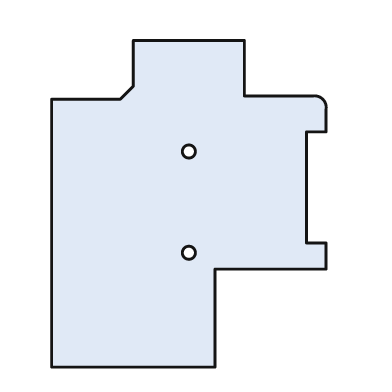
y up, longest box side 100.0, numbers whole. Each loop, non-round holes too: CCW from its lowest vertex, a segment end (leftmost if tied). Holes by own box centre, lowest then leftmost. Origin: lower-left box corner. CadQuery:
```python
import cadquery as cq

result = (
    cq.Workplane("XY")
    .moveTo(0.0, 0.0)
    .lineTo(50.0, 0.0)
    .lineTo(50.0, 30.0)
    .lineTo(84.0, 30.0)
    .lineTo(84.0, 38.0)
    .lineTo(78.0, 38.0)
    .lineTo(78.0, 72.0)
    .lineTo(84.0, 72.0)
    .lineTo(84.0, 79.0)
    .threePointArc((83.0, 82.0), (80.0, 83.0))
    .lineTo(59.0, 83.0)
    .lineTo(59.0, 100.0)
    .lineTo(25.0, 100.0)
    .lineTo(25.0, 86.0)
    .lineTo(21.0, 82.0)
    .lineTo(0.0, 82.0)
    .close()
    .moveTo(42.0, 35.0)
    .circle(2.0)
    .moveTo(42.0, 66.0)
    .circle(2.0)
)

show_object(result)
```